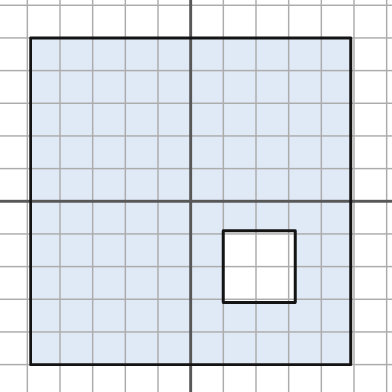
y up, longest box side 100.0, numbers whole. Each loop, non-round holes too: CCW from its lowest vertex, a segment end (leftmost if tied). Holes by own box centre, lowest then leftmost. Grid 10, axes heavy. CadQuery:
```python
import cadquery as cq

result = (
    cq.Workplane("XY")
    .moveTo(-49.0, -50.0)
    .lineTo(49.0, -50.0)
    .lineTo(49.0, 50.0)
    .lineTo(-49.0, 50.0)
    .close()
    .moveTo(10.0, -31.0)
    .lineTo(32.0, -31.0)
    .lineTo(32.0, -9.0)
    .lineTo(10.0, -9.0)
    .close()
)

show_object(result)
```